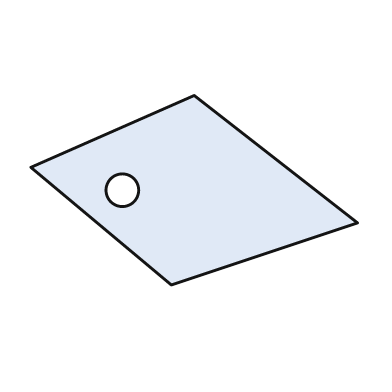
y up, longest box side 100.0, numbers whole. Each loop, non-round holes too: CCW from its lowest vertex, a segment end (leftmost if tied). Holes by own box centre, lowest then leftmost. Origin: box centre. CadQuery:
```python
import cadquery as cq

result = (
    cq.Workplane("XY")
    .moveTo(-7.0, -29.0)
    .lineTo(50.0, -10.0)
    .lineTo(0.0, 29.0)
    .lineTo(-50.0, 7.0)
    .close()
    .moveTo(-22.0, 0.0)
    .circle(5.0)
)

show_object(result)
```